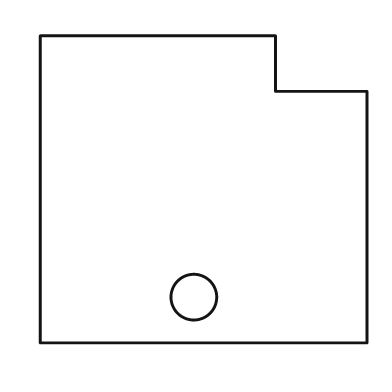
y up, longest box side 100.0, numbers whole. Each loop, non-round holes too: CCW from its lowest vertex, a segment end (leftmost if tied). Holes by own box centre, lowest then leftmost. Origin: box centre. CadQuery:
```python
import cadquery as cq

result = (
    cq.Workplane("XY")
    .moveTo(-50.0, -47.0)
    .lineTo(50.0, -47.0)
    .lineTo(50.0, 30.0)
    .lineTo(22.0, 30.0)
    .lineTo(22.0, 47.0)
    .lineTo(-50.0, 47.0)
    .close()
    .moveTo(-3.0, -33.0)
    .circle(7.0)
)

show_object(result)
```